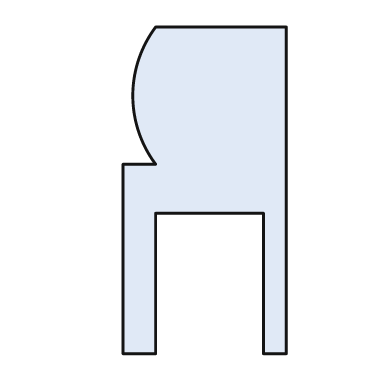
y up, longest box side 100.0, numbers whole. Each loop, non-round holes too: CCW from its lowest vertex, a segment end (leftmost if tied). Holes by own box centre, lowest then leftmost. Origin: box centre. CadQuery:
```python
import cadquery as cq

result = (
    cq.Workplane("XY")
    .moveTo(-25.0, -50.0)
    .lineTo(-15.0, -50.0)
    .lineTo(-15.0, -7.0)
    .lineTo(18.0, -7.0)
    .lineTo(18.0, -50.0)
    .lineTo(25.0, -50.0)
    .lineTo(25.0, 50.0)
    .lineTo(-15.0, 50.0)
    .threePointArc((-22.0, 29.0), (-15.0, 8.0))
    .lineTo(-25.0, 8.0)
    .close()
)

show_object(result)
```